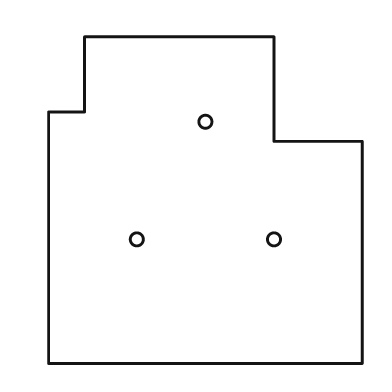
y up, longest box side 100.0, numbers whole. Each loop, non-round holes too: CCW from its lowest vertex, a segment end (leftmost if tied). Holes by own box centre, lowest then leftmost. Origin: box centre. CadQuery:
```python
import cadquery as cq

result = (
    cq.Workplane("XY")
    .moveTo(-48.0, -50.0)
    .lineTo(48.0, -50.0)
    .lineTo(48.0, 18.0)
    .lineTo(21.0, 18.0)
    .lineTo(21.0, 50.0)
    .lineTo(-37.0, 50.0)
    .lineTo(-37.0, 27.0)
    .lineTo(-48.0, 27.0)
    .close()
    .moveTo(-21.0, -12.0)
    .circle(2.0)
    .moveTo(21.0, -12.0)
    .circle(2.0)
    .moveTo(0.0, 24.0)
    .circle(2.0)
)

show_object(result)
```